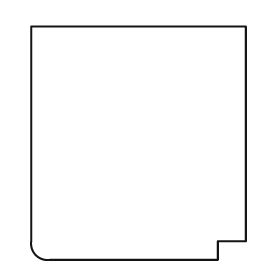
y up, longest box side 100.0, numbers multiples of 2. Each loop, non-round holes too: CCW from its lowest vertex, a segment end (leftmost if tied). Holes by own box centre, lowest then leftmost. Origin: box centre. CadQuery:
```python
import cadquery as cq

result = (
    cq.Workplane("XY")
    .moveTo(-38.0, -50.0)
    .lineTo(34.0, -50.0)
    .lineTo(34.0, -42.0)
    .lineTo(46.0, -42.0)
    .lineTo(46.0, 50.0)
    .lineTo(-46.0, 50.0)
    .lineTo(-46.0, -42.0)
    .threePointArc((-44.0, -48.0), (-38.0, -50.0))
    .close()
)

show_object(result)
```